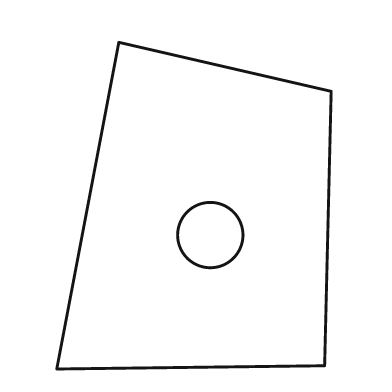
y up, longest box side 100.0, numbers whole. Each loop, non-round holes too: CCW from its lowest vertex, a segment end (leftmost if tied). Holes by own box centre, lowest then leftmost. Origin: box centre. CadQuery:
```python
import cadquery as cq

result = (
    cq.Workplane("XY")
    .moveTo(-42.0, -50.0)
    .lineTo(40.0, -49.0)
    .lineTo(42.0, 35.0)
    .lineTo(-23.0, 50.0)
    .close()
    .moveTo(5.0, -9.0)
    .circle(10.0)
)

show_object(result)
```